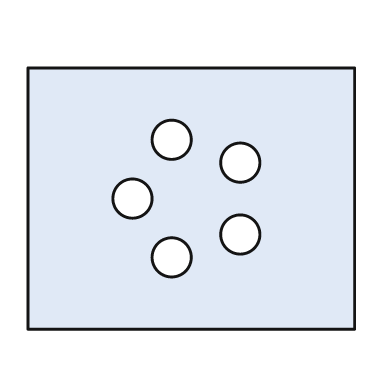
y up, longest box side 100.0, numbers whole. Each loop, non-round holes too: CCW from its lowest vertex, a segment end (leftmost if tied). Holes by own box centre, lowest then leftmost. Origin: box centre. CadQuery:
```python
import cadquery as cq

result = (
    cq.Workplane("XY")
    .moveTo(-50.0, -40.0)
    .lineTo(50.0, -40.0)
    .lineTo(50.0, 40.0)
    .lineTo(-50.0, 40.0)
    .close()
    .moveTo(-6.0, -18.0)
    .circle(6.0)
    .moveTo(15.0, -11.0)
    .circle(6.0)
    .moveTo(-18.0, 0.0)
    .circle(6.0)
    .moveTo(15.0, 11.0)
    .circle(6.0)
    .moveTo(-6.0, 18.0)
    .circle(6.0)
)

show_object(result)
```